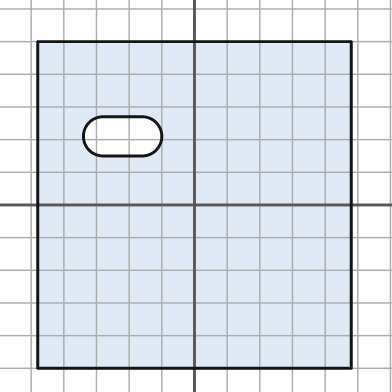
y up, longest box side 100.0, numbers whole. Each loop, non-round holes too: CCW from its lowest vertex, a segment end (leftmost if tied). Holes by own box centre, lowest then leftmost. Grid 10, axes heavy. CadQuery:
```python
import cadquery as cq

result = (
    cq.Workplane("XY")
    .moveTo(-48.0, -50.0)
    .lineTo(48.0, -50.0)
    .lineTo(48.0, 50.0)
    .lineTo(-48.0, 50.0)
    .close()
    .moveTo(-28.0, 15.0)
    .lineTo(-16.0, 15.0)
    .threePointArc((-10.0, 21.0), (-16.0, 27.0))
    .lineTo(-28.0, 27.0)
    .threePointArc((-34.0, 21.0), (-28.0, 15.0))
    .close()
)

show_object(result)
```